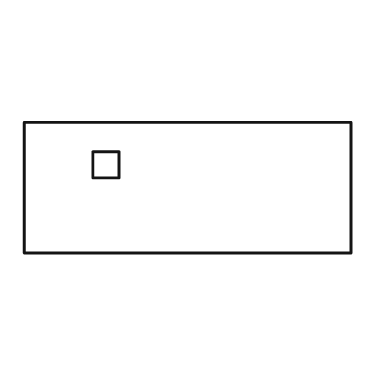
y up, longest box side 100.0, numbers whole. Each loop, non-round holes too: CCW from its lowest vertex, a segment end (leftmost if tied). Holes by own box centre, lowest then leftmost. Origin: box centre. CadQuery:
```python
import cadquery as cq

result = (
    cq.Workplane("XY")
    .moveTo(-50.0, -20.0)
    .lineTo(50.0, -20.0)
    .lineTo(50.0, 20.0)
    .lineTo(-50.0, 20.0)
    .close()
    .moveTo(-29.0, 3.0)
    .lineTo(-21.0, 3.0)
    .lineTo(-21.0, 11.0)
    .lineTo(-29.0, 11.0)
    .close()
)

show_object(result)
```